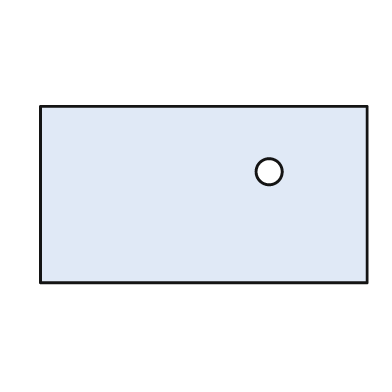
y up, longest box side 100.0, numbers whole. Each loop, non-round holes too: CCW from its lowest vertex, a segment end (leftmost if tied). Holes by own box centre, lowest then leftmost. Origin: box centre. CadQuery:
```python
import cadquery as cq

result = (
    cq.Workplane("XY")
    .moveTo(-50.0, -27.0)
    .lineTo(50.0, -27.0)
    .lineTo(50.0, 27.0)
    .lineTo(-50.0, 27.0)
    .close()
    .moveTo(20.0, 7.0)
    .circle(4.0)
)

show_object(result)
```